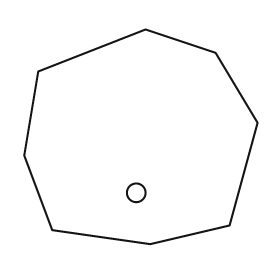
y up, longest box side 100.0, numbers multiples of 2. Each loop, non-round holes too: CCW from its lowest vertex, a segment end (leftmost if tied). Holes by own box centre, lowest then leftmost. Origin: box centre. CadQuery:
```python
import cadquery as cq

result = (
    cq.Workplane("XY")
    .moveTo(4.0, -46.0)
    .lineTo(38.0, -38.0)
    .lineTo(50.0, 6.0)
    .lineTo(32.0, 36.0)
    .lineTo(2.0, 46.0)
    .lineTo(-44.0, 28.0)
    .lineTo(-50.0, -8.0)
    .lineTo(-38.0, -40.0)
    .close()
    .moveTo(-2.0, -24.0)
    .circle(4.0)
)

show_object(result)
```